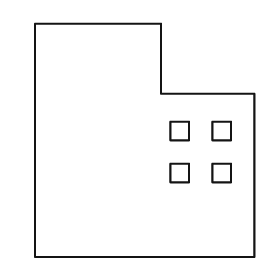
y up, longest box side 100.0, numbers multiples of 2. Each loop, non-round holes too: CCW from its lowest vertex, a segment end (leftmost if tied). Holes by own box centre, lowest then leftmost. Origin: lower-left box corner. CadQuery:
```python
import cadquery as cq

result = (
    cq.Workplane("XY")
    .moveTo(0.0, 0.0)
    .lineTo(94.0, 0.0)
    .lineTo(94.0, 70.0)
    .lineTo(54.0, 70.0)
    .lineTo(54.0, 100.0)
    .lineTo(0.0, 100.0)
    .close()
    .moveTo(58.0, 32.0)
    .lineTo(66.0, 32.0)
    .lineTo(66.0, 40.0)
    .lineTo(58.0, 40.0)
    .close()
    .moveTo(76.0, 32.0)
    .lineTo(84.0, 32.0)
    .lineTo(84.0, 40.0)
    .lineTo(76.0, 40.0)
    .close()
    .moveTo(58.0, 50.0)
    .lineTo(66.0, 50.0)
    .lineTo(66.0, 58.0)
    .lineTo(58.0, 58.0)
    .close()
    .moveTo(76.0, 50.0)
    .lineTo(84.0, 50.0)
    .lineTo(84.0, 58.0)
    .lineTo(76.0, 58.0)
    .close()
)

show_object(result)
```